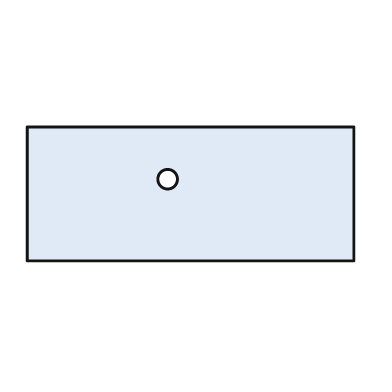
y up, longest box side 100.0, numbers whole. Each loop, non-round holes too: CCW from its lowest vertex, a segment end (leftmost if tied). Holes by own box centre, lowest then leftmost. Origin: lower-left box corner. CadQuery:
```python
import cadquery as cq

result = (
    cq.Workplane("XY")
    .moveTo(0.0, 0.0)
    .lineTo(100.0, 0.0)
    .lineTo(100.0, 41.0)
    .lineTo(0.0, 41.0)
    .close()
    .moveTo(43.0, 25.0)
    .circle(3.0)
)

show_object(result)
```